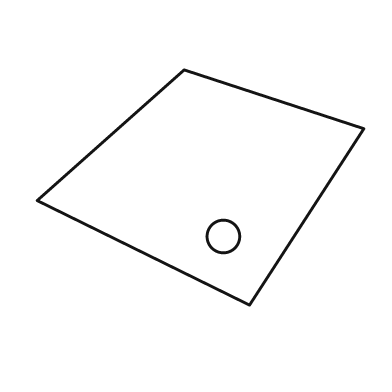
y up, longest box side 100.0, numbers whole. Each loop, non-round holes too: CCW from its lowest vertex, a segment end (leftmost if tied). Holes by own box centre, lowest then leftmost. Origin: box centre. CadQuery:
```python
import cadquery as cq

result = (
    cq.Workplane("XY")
    .moveTo(15.0, -36.0)
    .lineTo(50.0, 18.0)
    .lineTo(-5.0, 36.0)
    .lineTo(-50.0, -4.0)
    .close()
    .moveTo(7.0, -15.0)
    .circle(5.0)
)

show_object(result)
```